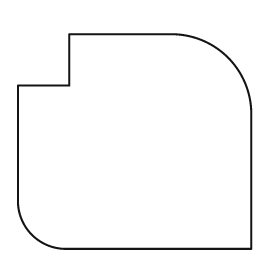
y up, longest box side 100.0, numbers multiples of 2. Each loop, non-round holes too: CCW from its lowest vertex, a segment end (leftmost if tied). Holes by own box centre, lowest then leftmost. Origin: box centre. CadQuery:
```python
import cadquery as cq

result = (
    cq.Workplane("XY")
    .moveTo(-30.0, -46.0)
    .lineTo(50.0, -46.0)
    .lineTo(50.0, 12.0)
    .threePointArc((40.0, 36.0), (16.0, 46.0))
    .lineTo(-28.0, 46.0)
    .lineTo(-28.0, 24.0)
    .lineTo(-50.0, 24.0)
    .lineTo(-50.0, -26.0)
    .threePointArc((-44.0, -40.0), (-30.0, -46.0))
    .close()
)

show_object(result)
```